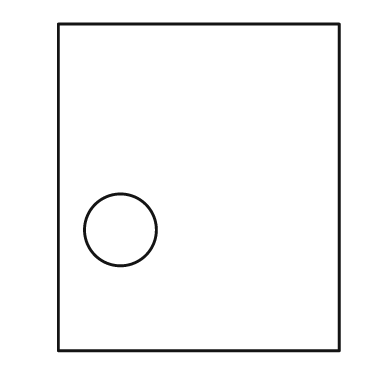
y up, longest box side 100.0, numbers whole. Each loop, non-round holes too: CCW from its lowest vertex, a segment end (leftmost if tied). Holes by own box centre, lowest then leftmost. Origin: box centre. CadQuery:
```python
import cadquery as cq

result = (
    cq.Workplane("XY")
    .moveTo(-43.0, -50.0)
    .lineTo(43.0, -50.0)
    .lineTo(43.0, 50.0)
    .lineTo(-43.0, 50.0)
    .close()
    .moveTo(-24.0, -13.0)
    .circle(11.0)
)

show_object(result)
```